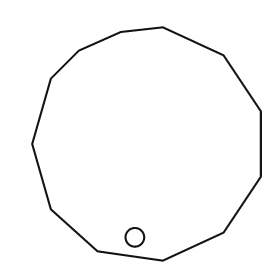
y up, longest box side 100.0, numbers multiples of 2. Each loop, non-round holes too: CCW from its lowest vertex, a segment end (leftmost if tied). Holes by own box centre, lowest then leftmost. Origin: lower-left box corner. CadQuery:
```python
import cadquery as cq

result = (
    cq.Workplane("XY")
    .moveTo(56.0, 0.0)
    .lineTo(82.0, 12.0)
    .lineTo(98.0, 36.0)
    .lineTo(98.0, 64.0)
    .lineTo(82.0, 88.0)
    .lineTo(56.0, 100.0)
    .lineTo(38.0, 98.0)
    .lineTo(20.0, 90.0)
    .lineTo(8.0, 78.0)
    .lineTo(0.0, 50.0)
    .lineTo(8.0, 22.0)
    .lineTo(28.0, 4.0)
    .close()
    .moveTo(44.0, 10.0)
    .circle(4.0)
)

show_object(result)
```